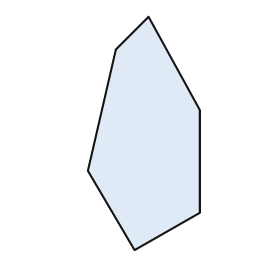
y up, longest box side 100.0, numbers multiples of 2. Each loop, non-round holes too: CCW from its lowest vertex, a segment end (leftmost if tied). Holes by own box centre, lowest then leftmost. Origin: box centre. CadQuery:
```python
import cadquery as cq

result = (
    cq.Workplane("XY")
    .moveTo(-4.0, -50.0)
    .lineTo(24.0, -34.0)
    .lineTo(24.0, 10.0)
    .lineTo(2.0, 50.0)
    .lineTo(-12.0, 36.0)
    .lineTo(-24.0, -16.0)
    .close()
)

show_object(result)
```